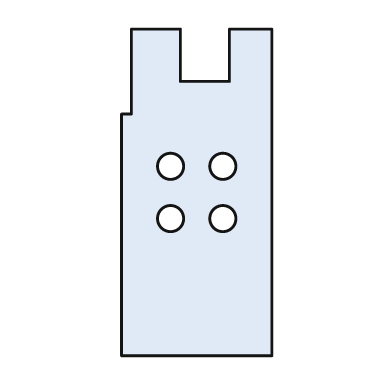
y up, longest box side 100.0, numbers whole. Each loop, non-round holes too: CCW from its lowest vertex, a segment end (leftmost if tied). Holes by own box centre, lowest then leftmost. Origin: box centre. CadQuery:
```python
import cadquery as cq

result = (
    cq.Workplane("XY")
    .moveTo(-23.0, -50.0)
    .lineTo(23.0, -50.0)
    .lineTo(23.0, 50.0)
    .lineTo(10.0, 50.0)
    .lineTo(10.0, 34.0)
    .lineTo(-5.0, 34.0)
    .lineTo(-5.0, 50.0)
    .lineTo(-20.0, 50.0)
    .lineTo(-20.0, 24.0)
    .lineTo(-23.0, 24.0)
    .close()
    .moveTo(-8.0, -8.0)
    .circle(4.0)
    .moveTo(8.0, -8.0)
    .circle(4.0)
    .moveTo(-8.0, 8.0)
    .circle(4.0)
    .moveTo(8.0, 8.0)
    .circle(4.0)
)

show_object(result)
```